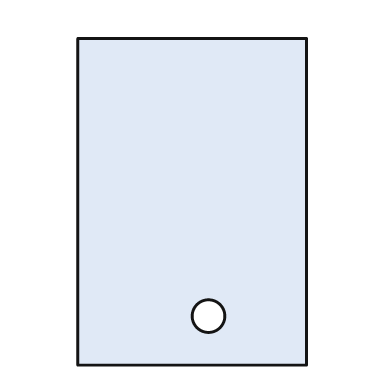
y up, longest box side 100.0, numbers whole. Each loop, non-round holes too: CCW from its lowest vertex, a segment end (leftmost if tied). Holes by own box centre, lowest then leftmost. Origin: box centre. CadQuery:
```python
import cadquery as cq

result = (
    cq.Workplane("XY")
    .moveTo(-35.0, -50.0)
    .lineTo(35.0, -50.0)
    .lineTo(35.0, 50.0)
    .lineTo(-35.0, 50.0)
    .close()
    .moveTo(5.0, -35.0)
    .circle(5.0)
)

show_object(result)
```